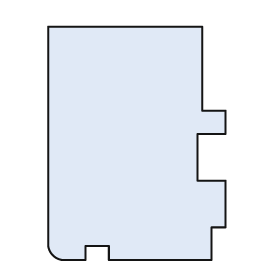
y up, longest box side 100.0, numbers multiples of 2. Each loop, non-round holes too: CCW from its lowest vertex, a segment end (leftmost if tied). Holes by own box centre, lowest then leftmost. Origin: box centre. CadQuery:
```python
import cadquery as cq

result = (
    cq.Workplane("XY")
    .moveTo(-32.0, -50.0)
    .lineTo(-22.0, -50.0)
    .lineTo(-22.0, -44.0)
    .lineTo(-12.0, -44.0)
    .lineTo(-12.0, -50.0)
    .lineTo(32.0, -50.0)
    .lineTo(32.0, -36.0)
    .lineTo(38.0, -36.0)
    .lineTo(38.0, -16.0)
    .lineTo(26.0, -16.0)
    .lineTo(26.0, 4.0)
    .lineTo(38.0, 4.0)
    .lineTo(38.0, 14.0)
    .lineTo(28.0, 14.0)
    .lineTo(28.0, 50.0)
    .lineTo(-38.0, 50.0)
    .lineTo(-38.0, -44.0)
    .threePointArc((-36.0, -48.0), (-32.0, -50.0))
    .close()
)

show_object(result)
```